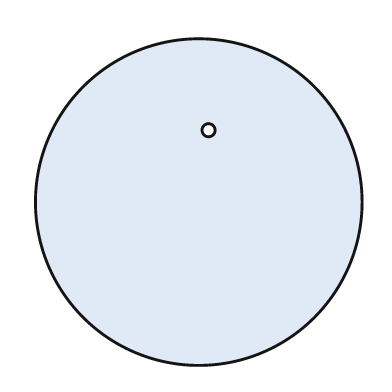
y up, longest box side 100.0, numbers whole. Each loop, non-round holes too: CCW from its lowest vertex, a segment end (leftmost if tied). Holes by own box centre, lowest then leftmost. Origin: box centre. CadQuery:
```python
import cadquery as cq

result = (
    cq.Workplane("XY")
    .moveTo(0.0, 0.0)
    .circle(50.0)
    .moveTo(3.0, 22.0)
    .circle(2.0)
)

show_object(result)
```